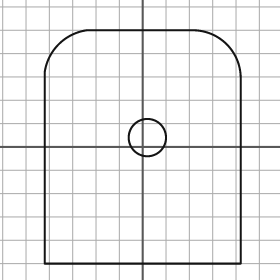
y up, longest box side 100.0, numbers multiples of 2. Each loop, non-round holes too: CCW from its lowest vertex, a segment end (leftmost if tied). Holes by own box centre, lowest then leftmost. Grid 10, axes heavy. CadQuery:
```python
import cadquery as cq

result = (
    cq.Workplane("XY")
    .moveTo(-42.0, -50.0)
    .lineTo(42.0, -50.0)
    .lineTo(42.0, 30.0)
    .threePointArc((36.0, 44.0), (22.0, 50.0))
    .lineTo(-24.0, 50.0)
    .threePointArc((-36.0, 44.0), (-42.0, 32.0))
    .close()
    .moveTo(2.0, 4.0)
    .circle(8.0)
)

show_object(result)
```